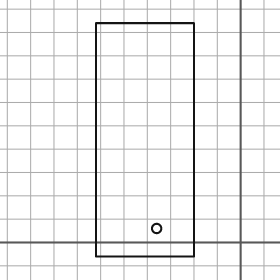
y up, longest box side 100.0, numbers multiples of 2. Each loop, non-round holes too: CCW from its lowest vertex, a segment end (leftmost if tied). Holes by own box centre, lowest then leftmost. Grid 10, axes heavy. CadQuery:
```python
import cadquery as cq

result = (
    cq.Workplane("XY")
    .moveTo(-62.0, -6.0)
    .lineTo(-20.0, -6.0)
    .lineTo(-20.0, 94.0)
    .lineTo(-62.0, 94.0)
    .close()
    .moveTo(-36.0, 6.0)
    .circle(2.0)
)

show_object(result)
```